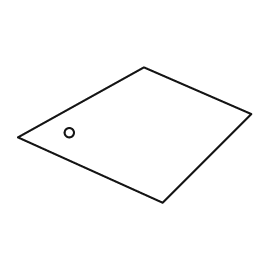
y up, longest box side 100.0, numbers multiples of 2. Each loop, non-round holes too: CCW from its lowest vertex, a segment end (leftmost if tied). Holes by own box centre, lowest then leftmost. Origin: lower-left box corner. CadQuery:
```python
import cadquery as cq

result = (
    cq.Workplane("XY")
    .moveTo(62.0, 0.0)
    .lineTo(100.0, 38.0)
    .lineTo(54.0, 58.0)
    .lineTo(0.0, 28.0)
    .close()
    .moveTo(22.0, 30.0)
    .circle(2.0)
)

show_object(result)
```